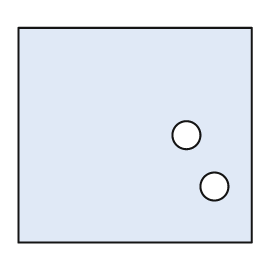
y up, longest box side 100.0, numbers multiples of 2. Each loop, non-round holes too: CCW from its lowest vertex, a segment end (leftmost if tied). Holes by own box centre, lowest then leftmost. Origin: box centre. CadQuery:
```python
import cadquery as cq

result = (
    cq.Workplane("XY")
    .moveTo(-50.0, -46.0)
    .lineTo(50.0, -46.0)
    .lineTo(50.0, 46.0)
    .lineTo(-50.0, 46.0)
    .close()
    .moveTo(34.0, -22.0)
    .circle(6.0)
    .moveTo(22.0, 0.0)
    .circle(6.0)
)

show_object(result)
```